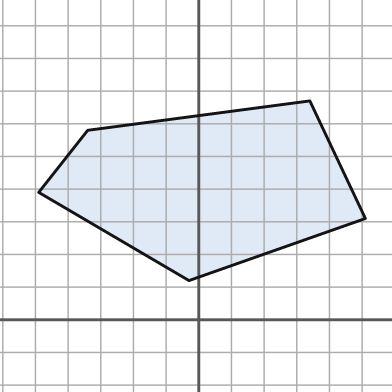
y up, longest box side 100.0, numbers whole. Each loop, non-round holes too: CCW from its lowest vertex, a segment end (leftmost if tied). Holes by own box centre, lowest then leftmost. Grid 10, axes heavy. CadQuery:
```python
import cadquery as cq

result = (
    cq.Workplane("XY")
    .moveTo(-3.0, 12.0)
    .lineTo(51.0, 31.0)
    .lineTo(34.0, 67.0)
    .lineTo(-34.0, 58.0)
    .lineTo(-49.0, 39.0)
    .close()
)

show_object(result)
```